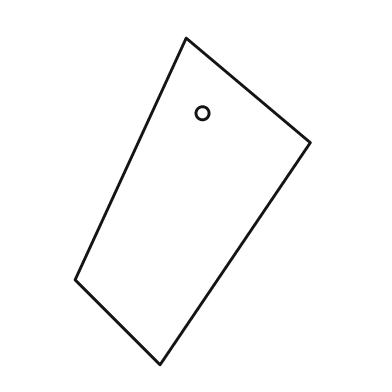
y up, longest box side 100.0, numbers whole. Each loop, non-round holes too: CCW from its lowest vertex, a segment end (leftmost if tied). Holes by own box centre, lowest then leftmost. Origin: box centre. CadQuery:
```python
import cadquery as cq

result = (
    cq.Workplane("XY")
    .moveTo(-10.0, -50.0)
    .lineTo(36.0, 18.0)
    .lineTo(-2.0, 50.0)
    .lineTo(-36.0, -24.0)
    .close()
    .moveTo(3.0, 27.0)
    .circle(2.0)
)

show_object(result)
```